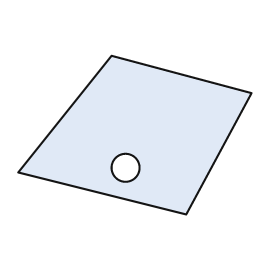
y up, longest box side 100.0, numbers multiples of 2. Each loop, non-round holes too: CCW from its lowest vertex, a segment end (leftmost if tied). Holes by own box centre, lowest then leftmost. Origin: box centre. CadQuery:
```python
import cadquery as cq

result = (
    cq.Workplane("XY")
    .moveTo(22.0, -34.0)
    .lineTo(50.0, 18.0)
    .lineTo(-10.0, 34.0)
    .lineTo(-50.0, -16.0)
    .close()
    .moveTo(-4.0, -14.0)
    .circle(6.0)
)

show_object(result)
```